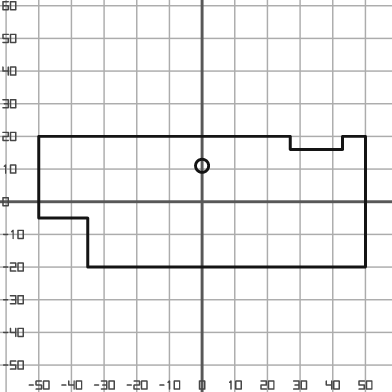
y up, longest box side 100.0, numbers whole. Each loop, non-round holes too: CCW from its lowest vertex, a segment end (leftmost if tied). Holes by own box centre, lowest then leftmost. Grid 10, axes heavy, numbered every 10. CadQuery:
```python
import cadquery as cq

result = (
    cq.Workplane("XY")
    .moveTo(-35.0, -20.0)
    .lineTo(50.0, -20.0)
    .lineTo(50.0, 20.0)
    .lineTo(43.0, 20.0)
    .lineTo(43.0, 16.0)
    .lineTo(27.0, 16.0)
    .lineTo(27.0, 20.0)
    .lineTo(-50.0, 20.0)
    .lineTo(-50.0, -5.0)
    .lineTo(-35.0, -5.0)
    .close()
    .moveTo(0.0, 11.0)
    .circle(2.0)
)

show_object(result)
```